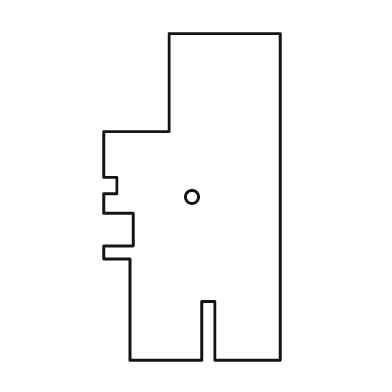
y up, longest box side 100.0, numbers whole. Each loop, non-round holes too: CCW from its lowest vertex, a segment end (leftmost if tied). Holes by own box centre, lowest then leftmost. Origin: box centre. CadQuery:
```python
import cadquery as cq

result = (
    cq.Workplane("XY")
    .moveTo(-19.0, -50.0)
    .lineTo(3.0, -50.0)
    .lineTo(3.0, -32.0)
    .lineTo(7.0, -32.0)
    .lineTo(7.0, -50.0)
    .lineTo(27.0, -50.0)
    .lineTo(27.0, 50.0)
    .lineTo(-7.0, 50.0)
    .lineTo(-7.0, 20.0)
    .lineTo(-27.0, 20.0)
    .lineTo(-27.0, 6.0)
    .lineTo(-23.0, 6.0)
    .lineTo(-23.0, 1.0)
    .lineTo(-27.0, 1.0)
    .lineTo(-27.0, -5.0)
    .lineTo(-18.0, -5.0)
    .lineTo(-18.0, -15.0)
    .lineTo(-27.0, -15.0)
    .lineTo(-27.0, -19.0)
    .lineTo(-19.0, -19.0)
    .close()
    .moveTo(0.0, 0.0)
    .circle(2.0)
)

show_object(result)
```